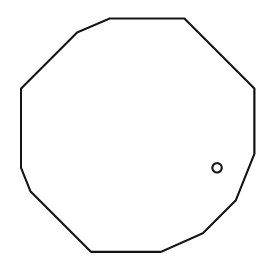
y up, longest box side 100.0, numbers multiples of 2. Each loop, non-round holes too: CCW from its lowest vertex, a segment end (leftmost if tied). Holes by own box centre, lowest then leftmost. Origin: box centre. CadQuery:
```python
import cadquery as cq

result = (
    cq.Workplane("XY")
    .moveTo(-20.0, -50.0)
    .lineTo(10.0, -50.0)
    .lineTo(28.0, -42.0)
    .lineTo(42.0, -28.0)
    .lineTo(50.0, -8.0)
    .lineTo(50.0, 20.0)
    .lineTo(20.0, 50.0)
    .lineTo(-12.0, 50.0)
    .lineTo(-26.0, 44.0)
    .lineTo(-50.0, 20.0)
    .lineTo(-50.0, -14.0)
    .lineTo(-46.0, -24.0)
    .close()
    .moveTo(34.0, -14.0)
    .circle(2.0)
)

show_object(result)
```